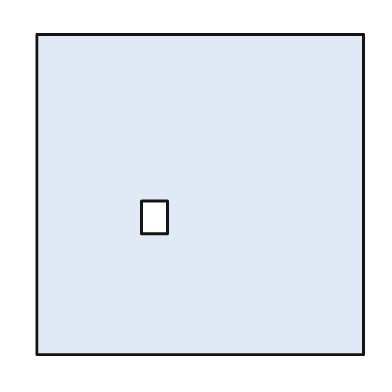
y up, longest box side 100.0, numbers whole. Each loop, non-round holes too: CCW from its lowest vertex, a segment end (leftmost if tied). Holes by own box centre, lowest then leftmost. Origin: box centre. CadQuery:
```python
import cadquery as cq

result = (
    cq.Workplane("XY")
    .moveTo(-50.0, -49.0)
    .lineTo(50.0, -49.0)
    .lineTo(50.0, 49.0)
    .lineTo(-50.0, 49.0)
    .close()
    .moveTo(-18.0, -12.0)
    .lineTo(-10.0, -12.0)
    .lineTo(-10.0, -2.0)
    .lineTo(-18.0, -2.0)
    .close()
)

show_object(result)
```